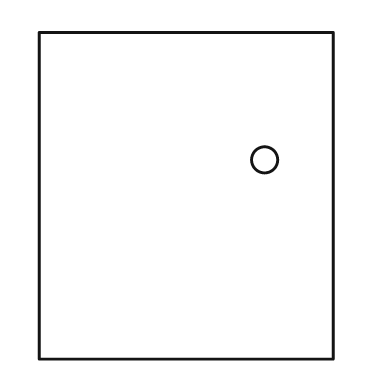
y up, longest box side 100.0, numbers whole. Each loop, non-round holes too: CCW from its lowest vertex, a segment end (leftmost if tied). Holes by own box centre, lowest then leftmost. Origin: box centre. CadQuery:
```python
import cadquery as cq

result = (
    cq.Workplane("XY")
    .moveTo(-45.0, -50.0)
    .lineTo(45.0, -50.0)
    .lineTo(45.0, 50.0)
    .lineTo(-45.0, 50.0)
    .close()
    .moveTo(24.0, 11.0)
    .circle(4.0)
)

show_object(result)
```